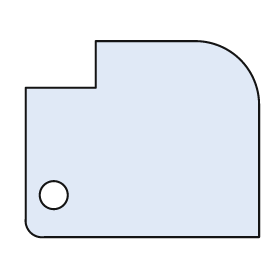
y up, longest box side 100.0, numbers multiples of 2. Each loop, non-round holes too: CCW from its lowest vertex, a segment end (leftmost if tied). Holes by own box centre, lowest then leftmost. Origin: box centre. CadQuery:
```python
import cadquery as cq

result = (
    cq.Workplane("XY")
    .moveTo(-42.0, -42.0)
    .lineTo(50.0, -42.0)
    .lineTo(50.0, 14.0)
    .threePointArc((42.0, 34.0), (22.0, 42.0))
    .lineTo(-20.0, 42.0)
    .lineTo(-20.0, 22.0)
    .lineTo(-50.0, 22.0)
    .lineTo(-50.0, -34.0)
    .threePointArc((-48.0, -40.0), (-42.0, -42.0))
    .close()
    .moveTo(-38.0, -24.0)
    .circle(6.0)
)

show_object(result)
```